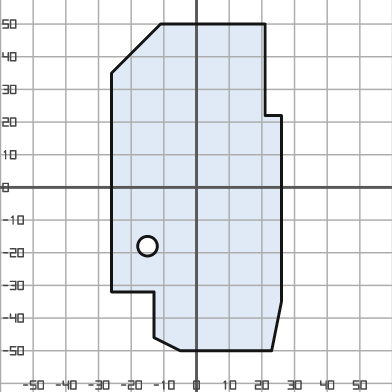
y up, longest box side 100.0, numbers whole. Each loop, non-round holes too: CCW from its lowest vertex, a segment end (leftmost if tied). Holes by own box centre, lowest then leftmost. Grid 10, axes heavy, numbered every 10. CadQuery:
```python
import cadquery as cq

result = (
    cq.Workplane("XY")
    .moveTo(-5.0, -50.0)
    .lineTo(23.0, -50.0)
    .lineTo(26.0, -35.0)
    .lineTo(26.0, 22.0)
    .lineTo(21.0, 22.0)
    .lineTo(21.0, 50.0)
    .lineTo(-11.0, 50.0)
    .lineTo(-26.0, 35.0)
    .lineTo(-26.0, -32.0)
    .lineTo(-13.0, -32.0)
    .lineTo(-13.0, -46.0)
    .close()
    .moveTo(-15.0, -18.0)
    .circle(3.0)
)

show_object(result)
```